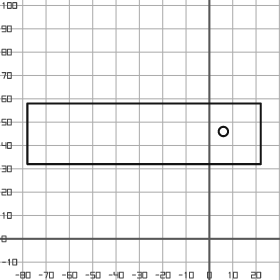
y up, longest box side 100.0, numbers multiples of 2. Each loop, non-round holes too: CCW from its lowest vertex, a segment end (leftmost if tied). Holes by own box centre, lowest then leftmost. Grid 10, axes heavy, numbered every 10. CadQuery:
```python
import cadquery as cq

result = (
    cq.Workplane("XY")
    .moveTo(-78.0, 32.0)
    .lineTo(22.0, 32.0)
    .lineTo(22.0, 58.0)
    .lineTo(-78.0, 58.0)
    .close()
    .moveTo(6.0, 46.0)
    .circle(2.0)
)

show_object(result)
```